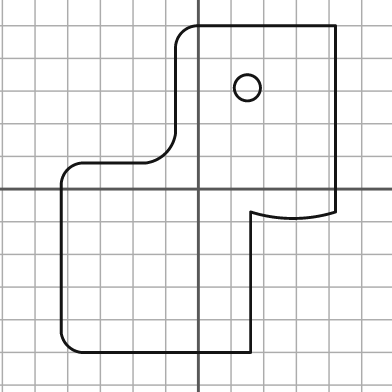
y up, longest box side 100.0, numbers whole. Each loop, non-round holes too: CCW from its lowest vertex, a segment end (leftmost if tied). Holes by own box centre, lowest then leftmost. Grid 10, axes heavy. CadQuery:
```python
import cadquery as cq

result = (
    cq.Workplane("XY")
    .moveTo(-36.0, -50.0)
    .lineTo(16.0, -50.0)
    .lineTo(16.0, -7.0)
    .threePointArc((29.0, -9.0), (42.0, -7.0))
    .lineTo(42.0, 50.0)
    .lineTo(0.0, 50.0)
    .threePointArc((-5.0, 48.0), (-7.0, 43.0))
    .lineTo(-7.0, 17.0)
    .threePointArc((-10.0, 11.0), (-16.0, 8.0))
    .lineTo(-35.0, 8.0)
    .threePointArc((-40.0, 6.0), (-42.0, 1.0))
    .lineTo(-42.0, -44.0)
    .threePointArc((-40.0, -48.0), (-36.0, -50.0))
    .close()
    .moveTo(15.0, 31.0)
    .circle(4.0)
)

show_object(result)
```